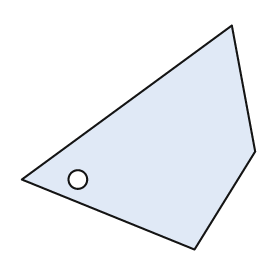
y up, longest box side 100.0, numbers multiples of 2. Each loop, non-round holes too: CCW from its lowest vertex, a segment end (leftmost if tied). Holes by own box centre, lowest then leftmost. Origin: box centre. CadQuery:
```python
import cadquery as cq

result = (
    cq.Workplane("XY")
    .moveTo(24.0, -48.0)
    .lineTo(50.0, -6.0)
    .lineTo(40.0, 48.0)
    .lineTo(-50.0, -18.0)
    .close()
    .moveTo(-26.0, -18.0)
    .circle(4.0)
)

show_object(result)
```